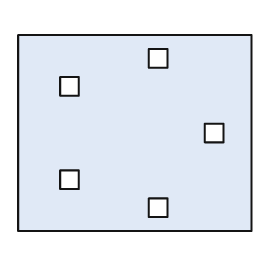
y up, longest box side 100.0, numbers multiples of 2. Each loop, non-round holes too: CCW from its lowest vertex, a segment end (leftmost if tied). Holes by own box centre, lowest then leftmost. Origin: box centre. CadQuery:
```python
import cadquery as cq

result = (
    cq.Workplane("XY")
    .moveTo(-50.0, -42.0)
    .lineTo(50.0, -42.0)
    .lineTo(50.0, 42.0)
    .lineTo(-50.0, 42.0)
    .close()
    .moveTo(6.0, -36.0)
    .lineTo(14.0, -36.0)
    .lineTo(14.0, -28.0)
    .lineTo(6.0, -28.0)
    .close()
    .moveTo(-32.0, -24.0)
    .lineTo(-24.0, -24.0)
    .lineTo(-24.0, -16.0)
    .lineTo(-32.0, -16.0)
    .close()
    .moveTo(30.0, -4.0)
    .lineTo(38.0, -4.0)
    .lineTo(38.0, 4.0)
    .lineTo(30.0, 4.0)
    .close()
    .moveTo(-32.0, 16.0)
    .lineTo(-24.0, 16.0)
    .lineTo(-24.0, 24.0)
    .lineTo(-32.0, 24.0)
    .close()
    .moveTo(6.0, 28.0)
    .lineTo(14.0, 28.0)
    .lineTo(14.0, 36.0)
    .lineTo(6.0, 36.0)
    .close()
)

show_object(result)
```